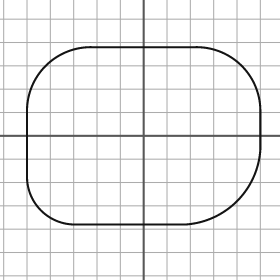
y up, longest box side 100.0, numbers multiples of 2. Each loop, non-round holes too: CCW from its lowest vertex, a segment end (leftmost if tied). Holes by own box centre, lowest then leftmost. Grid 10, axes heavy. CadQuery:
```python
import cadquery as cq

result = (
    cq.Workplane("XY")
    .moveTo(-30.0, -38.0)
    .lineTo(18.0, -38.0)
    .threePointArc((40.0, -28.0), (50.0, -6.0))
    .lineTo(50.0, 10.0)
    .threePointArc((42.0, 30.0), (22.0, 38.0))
    .lineTo(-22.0, 38.0)
    .threePointArc((-42.0, 30.0), (-50.0, 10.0))
    .lineTo(-50.0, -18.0)
    .threePointArc((-44.0, -32.0), (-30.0, -38.0))
    .close()
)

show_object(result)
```